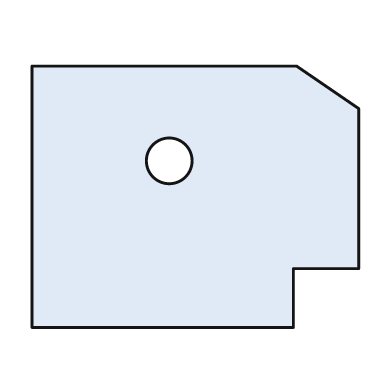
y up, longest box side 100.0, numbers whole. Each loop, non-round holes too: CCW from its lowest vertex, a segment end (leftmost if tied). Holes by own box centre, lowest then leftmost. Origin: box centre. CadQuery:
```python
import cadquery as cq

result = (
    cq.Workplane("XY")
    .moveTo(-50.0, -40.0)
    .lineTo(30.0, -40.0)
    .lineTo(30.0, -22.0)
    .lineTo(50.0, -22.0)
    .lineTo(50.0, 27.0)
    .lineTo(31.0, 40.0)
    .lineTo(-50.0, 40.0)
    .close()
    .moveTo(-8.0, 11.0)
    .circle(7.0)
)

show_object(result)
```